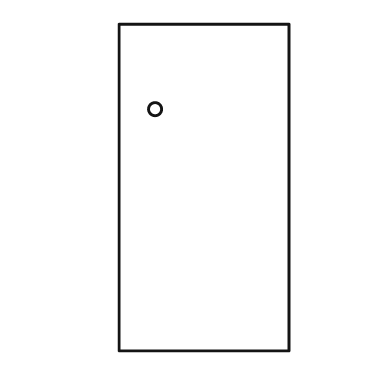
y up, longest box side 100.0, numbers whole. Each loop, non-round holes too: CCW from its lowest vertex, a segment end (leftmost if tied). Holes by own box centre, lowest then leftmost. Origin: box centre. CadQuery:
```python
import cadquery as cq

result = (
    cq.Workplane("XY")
    .moveTo(-26.0, -50.0)
    .lineTo(26.0, -50.0)
    .lineTo(26.0, 50.0)
    .lineTo(-26.0, 50.0)
    .close()
    .moveTo(-15.0, 24.0)
    .circle(2.0)
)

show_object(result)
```